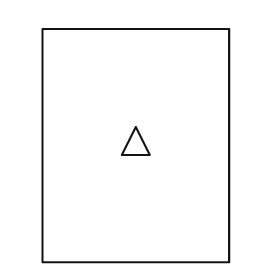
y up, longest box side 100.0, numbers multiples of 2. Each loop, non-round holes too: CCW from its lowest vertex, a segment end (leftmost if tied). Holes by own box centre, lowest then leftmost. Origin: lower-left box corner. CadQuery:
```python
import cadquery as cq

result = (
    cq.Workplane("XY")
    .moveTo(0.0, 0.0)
    .lineTo(80.0, 0.0)
    .lineTo(80.0, 100.0)
    .lineTo(0.0, 100.0)
    .close()
    .moveTo(34.0, 46.0)
    .lineTo(46.0, 46.0)
    .lineTo(40.0, 58.0)
    .close()
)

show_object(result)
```